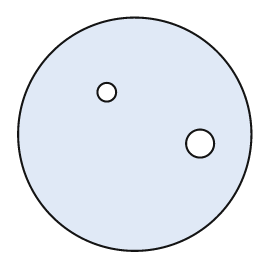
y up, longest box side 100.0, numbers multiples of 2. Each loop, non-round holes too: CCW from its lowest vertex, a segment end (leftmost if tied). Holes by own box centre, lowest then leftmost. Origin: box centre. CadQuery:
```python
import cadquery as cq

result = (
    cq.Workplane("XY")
    .moveTo(0.0, 0.0)
    .circle(50.0)
    .moveTo(28.0, -4.0)
    .circle(6.0)
    .moveTo(-12.0, 18.0)
    .circle(4.0)
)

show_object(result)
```